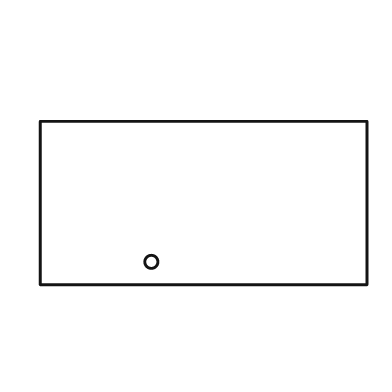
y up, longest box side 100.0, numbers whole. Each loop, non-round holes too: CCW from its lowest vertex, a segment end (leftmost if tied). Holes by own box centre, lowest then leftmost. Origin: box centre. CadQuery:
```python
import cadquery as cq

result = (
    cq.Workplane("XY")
    .moveTo(-50.0, -25.0)
    .lineTo(50.0, -25.0)
    .lineTo(50.0, 25.0)
    .lineTo(-50.0, 25.0)
    .close()
    .moveTo(-16.0, -18.0)
    .circle(2.0)
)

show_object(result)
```